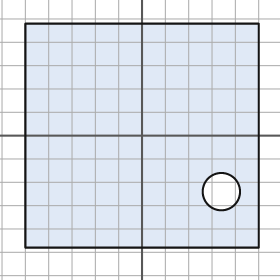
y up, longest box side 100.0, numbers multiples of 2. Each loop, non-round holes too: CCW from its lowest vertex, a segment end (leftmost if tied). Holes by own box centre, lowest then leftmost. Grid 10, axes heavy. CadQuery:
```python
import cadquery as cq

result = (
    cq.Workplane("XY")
    .moveTo(-50.0, -48.0)
    .lineTo(50.0, -48.0)
    .lineTo(50.0, 48.0)
    .lineTo(-50.0, 48.0)
    .close()
    .moveTo(34.0, -24.0)
    .circle(8.0)
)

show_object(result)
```